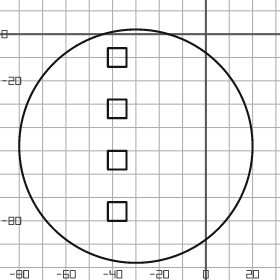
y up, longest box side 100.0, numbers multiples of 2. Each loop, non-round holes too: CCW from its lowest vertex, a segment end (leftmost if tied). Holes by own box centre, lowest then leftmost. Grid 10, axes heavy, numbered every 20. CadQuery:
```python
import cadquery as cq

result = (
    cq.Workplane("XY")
    .moveTo(-30.0, -48.0)
    .circle(50.0)
    .moveTo(-42.0, -80.0)
    .lineTo(-34.0, -80.0)
    .lineTo(-34.0, -72.0)
    .lineTo(-42.0, -72.0)
    .close()
    .moveTo(-42.0, -58.0)
    .lineTo(-34.0, -58.0)
    .lineTo(-34.0, -50.0)
    .lineTo(-42.0, -50.0)
    .close()
    .moveTo(-42.0, -36.0)
    .lineTo(-34.0, -36.0)
    .lineTo(-34.0, -28.0)
    .lineTo(-42.0, -28.0)
    .close()
    .moveTo(-42.0, -14.0)
    .lineTo(-34.0, -14.0)
    .lineTo(-34.0, -6.0)
    .lineTo(-42.0, -6.0)
    .close()
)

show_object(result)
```